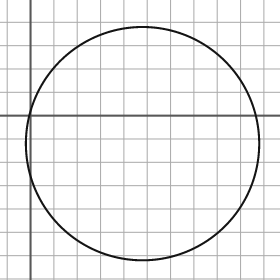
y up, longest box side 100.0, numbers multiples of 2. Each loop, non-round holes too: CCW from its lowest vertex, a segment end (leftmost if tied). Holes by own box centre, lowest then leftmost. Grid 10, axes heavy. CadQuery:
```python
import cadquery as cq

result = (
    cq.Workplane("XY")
    .moveTo(48.0, -12.0)
    .circle(50.0)
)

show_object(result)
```